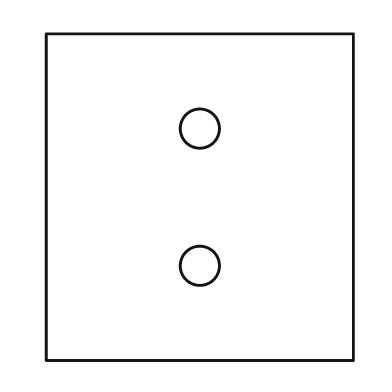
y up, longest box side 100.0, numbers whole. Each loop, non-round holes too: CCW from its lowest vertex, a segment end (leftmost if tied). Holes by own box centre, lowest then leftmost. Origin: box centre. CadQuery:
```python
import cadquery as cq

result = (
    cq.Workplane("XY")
    .moveTo(-47.0, -50.0)
    .lineTo(47.0, -50.0)
    .lineTo(47.0, 50.0)
    .lineTo(-47.0, 50.0)
    .close()
    .moveTo(0.0, -21.0)
    .circle(6.0)
    .moveTo(0.0, 21.0)
    .circle(6.0)
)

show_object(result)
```